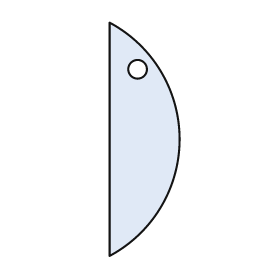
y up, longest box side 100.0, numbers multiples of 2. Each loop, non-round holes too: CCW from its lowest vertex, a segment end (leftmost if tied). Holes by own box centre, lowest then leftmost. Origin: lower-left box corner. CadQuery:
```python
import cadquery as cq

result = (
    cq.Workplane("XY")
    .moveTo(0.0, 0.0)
    .threePointArc((30.0, 50.0), (0.0, 100.0))
    .close()
    .moveTo(12.0, 80.0)
    .circle(4.0)
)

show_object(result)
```